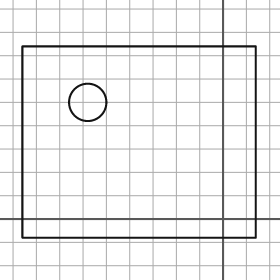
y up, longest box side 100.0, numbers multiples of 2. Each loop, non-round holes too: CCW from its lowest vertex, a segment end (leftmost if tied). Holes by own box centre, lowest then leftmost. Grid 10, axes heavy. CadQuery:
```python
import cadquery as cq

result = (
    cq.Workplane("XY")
    .moveTo(-86.0, -8.0)
    .lineTo(14.0, -8.0)
    .lineTo(14.0, 74.0)
    .lineTo(-86.0, 74.0)
    .close()
    .moveTo(-58.0, 50.0)
    .circle(8.0)
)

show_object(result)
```